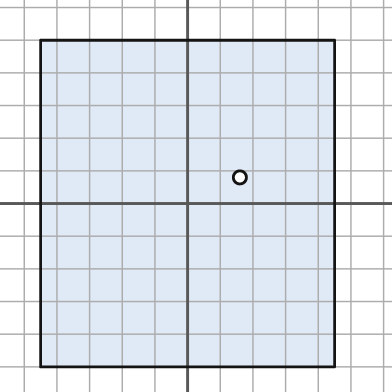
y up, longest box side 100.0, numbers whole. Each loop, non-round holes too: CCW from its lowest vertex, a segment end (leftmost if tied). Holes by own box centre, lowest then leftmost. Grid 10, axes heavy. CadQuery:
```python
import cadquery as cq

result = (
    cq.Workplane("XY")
    .moveTo(-45.0, -50.0)
    .lineTo(45.0, -50.0)
    .lineTo(45.0, 50.0)
    .lineTo(-45.0, 50.0)
    .close()
    .moveTo(16.0, 8.0)
    .circle(2.0)
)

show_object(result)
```